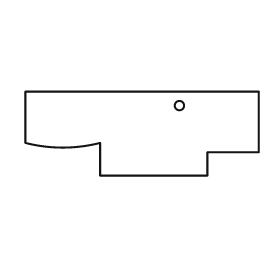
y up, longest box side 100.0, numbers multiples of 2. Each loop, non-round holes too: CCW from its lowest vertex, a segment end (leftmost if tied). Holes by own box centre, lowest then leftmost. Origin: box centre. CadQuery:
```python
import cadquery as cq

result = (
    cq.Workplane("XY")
    .moveTo(-18.0, -18.0)
    .lineTo(28.0, -18.0)
    .lineTo(28.0, -8.0)
    .lineTo(50.0, -8.0)
    .lineTo(50.0, 18.0)
    .lineTo(-50.0, 18.0)
    .lineTo(-50.0, -4.0)
    .threePointArc((-34.0, -6.0), (-18.0, -4.0))
    .close()
    .moveTo(16.0, 12.0)
    .circle(2.0)
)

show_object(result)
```